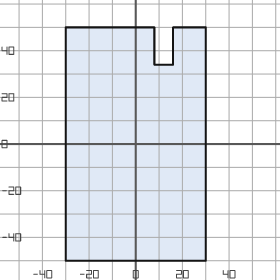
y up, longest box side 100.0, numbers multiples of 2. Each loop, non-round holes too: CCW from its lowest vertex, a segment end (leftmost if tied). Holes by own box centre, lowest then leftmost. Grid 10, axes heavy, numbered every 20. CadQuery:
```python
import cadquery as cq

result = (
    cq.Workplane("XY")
    .moveTo(-30.0, -50.0)
    .lineTo(30.0, -50.0)
    .lineTo(30.0, 50.0)
    .lineTo(16.0, 50.0)
    .lineTo(16.0, 34.0)
    .lineTo(8.0, 34.0)
    .lineTo(8.0, 50.0)
    .lineTo(-30.0, 50.0)
    .close()
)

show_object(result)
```